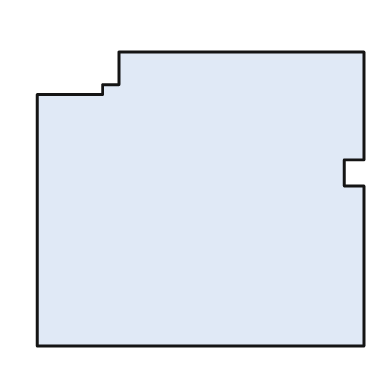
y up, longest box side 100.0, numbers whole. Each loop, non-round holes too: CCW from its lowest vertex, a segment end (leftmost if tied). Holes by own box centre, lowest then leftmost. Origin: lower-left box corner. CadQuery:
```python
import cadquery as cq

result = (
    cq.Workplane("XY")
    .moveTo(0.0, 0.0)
    .lineTo(100.0, 0.0)
    .lineTo(100.0, 49.0)
    .lineTo(94.0, 49.0)
    .lineTo(94.0, 57.0)
    .lineTo(100.0, 57.0)
    .lineTo(100.0, 90.0)
    .lineTo(25.0, 90.0)
    .lineTo(25.0, 80.0)
    .lineTo(20.0, 80.0)
    .lineTo(20.0, 77.0)
    .lineTo(0.0, 77.0)
    .close()
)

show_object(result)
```